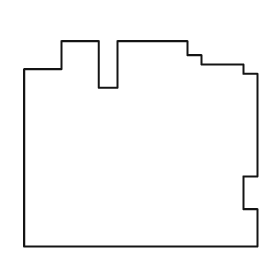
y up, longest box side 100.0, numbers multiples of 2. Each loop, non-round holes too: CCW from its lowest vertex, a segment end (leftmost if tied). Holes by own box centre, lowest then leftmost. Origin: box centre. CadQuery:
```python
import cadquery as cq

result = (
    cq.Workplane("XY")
    .moveTo(-50.0, -44.0)
    .lineTo(50.0, -44.0)
    .lineTo(50.0, -28.0)
    .lineTo(44.0, -28.0)
    .lineTo(44.0, -14.0)
    .lineTo(50.0, -14.0)
    .lineTo(50.0, 30.0)
    .lineTo(44.0, 30.0)
    .lineTo(44.0, 34.0)
    .lineTo(26.0, 34.0)
    .lineTo(26.0, 38.0)
    .lineTo(20.0, 38.0)
    .lineTo(20.0, 44.0)
    .lineTo(-10.0, 44.0)
    .lineTo(-10.0, 24.0)
    .lineTo(-18.0, 24.0)
    .lineTo(-18.0, 44.0)
    .lineTo(-34.0, 44.0)
    .lineTo(-34.0, 32.0)
    .lineTo(-50.0, 32.0)
    .close()
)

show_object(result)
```